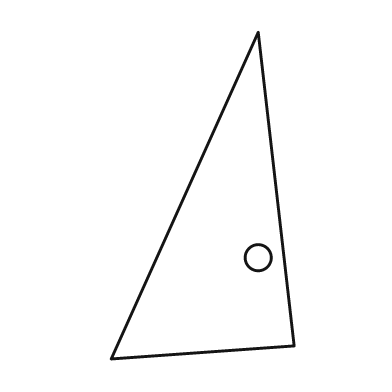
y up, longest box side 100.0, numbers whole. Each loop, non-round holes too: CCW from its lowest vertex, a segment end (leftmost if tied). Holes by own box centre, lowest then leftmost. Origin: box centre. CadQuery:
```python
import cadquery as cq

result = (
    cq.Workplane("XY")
    .moveTo(-28.0, -50.0)
    .lineTo(28.0, -46.0)
    .lineTo(17.0, 50.0)
    .close()
    .moveTo(17.0, -19.0)
    .circle(4.0)
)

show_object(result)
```